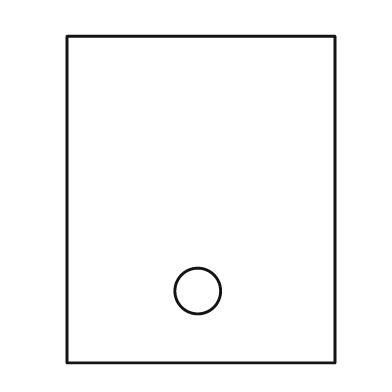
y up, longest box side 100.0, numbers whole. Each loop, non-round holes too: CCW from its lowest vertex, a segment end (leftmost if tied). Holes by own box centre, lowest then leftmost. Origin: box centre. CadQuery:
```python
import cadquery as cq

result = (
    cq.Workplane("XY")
    .moveTo(-41.0, -50.0)
    .lineTo(41.0, -50.0)
    .lineTo(41.0, 50.0)
    .lineTo(-41.0, 50.0)
    .close()
    .moveTo(-1.0, -28.0)
    .circle(7.0)
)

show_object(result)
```